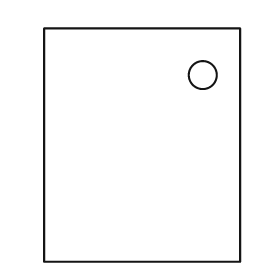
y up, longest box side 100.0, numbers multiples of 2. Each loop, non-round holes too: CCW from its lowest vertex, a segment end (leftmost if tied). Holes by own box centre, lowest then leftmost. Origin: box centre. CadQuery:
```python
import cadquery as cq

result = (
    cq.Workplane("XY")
    .moveTo(-42.0, -50.0)
    .lineTo(42.0, -50.0)
    .lineTo(42.0, 50.0)
    .lineTo(-42.0, 50.0)
    .close()
    .moveTo(26.0, 30.0)
    .circle(6.0)
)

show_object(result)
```